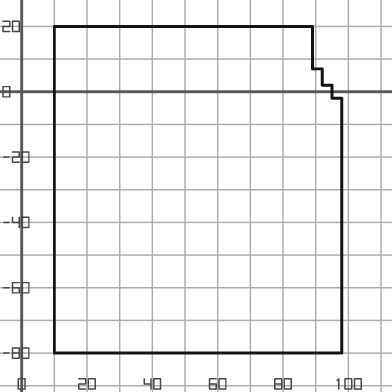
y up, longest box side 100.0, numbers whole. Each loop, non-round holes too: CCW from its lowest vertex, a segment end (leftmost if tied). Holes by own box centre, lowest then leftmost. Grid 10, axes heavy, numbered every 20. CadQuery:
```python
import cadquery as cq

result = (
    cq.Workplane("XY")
    .moveTo(10.0, -80.0)
    .lineTo(98.0, -80.0)
    .lineTo(98.0, -2.0)
    .lineTo(95.0, -2.0)
    .lineTo(95.0, 2.0)
    .lineTo(92.0, 2.0)
    .lineTo(92.0, 7.0)
    .lineTo(89.0, 7.0)
    .lineTo(89.0, 20.0)
    .lineTo(10.0, 20.0)
    .close()
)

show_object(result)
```